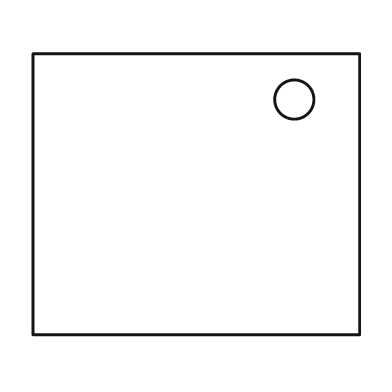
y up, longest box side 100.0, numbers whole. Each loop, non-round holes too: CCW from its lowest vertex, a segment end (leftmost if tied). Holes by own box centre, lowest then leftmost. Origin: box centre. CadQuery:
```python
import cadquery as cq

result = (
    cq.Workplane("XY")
    .moveTo(-50.0, -43.0)
    .lineTo(50.0, -43.0)
    .lineTo(50.0, 43.0)
    .lineTo(-50.0, 43.0)
    .close()
    .moveTo(30.0, 29.0)
    .circle(6.0)
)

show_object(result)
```